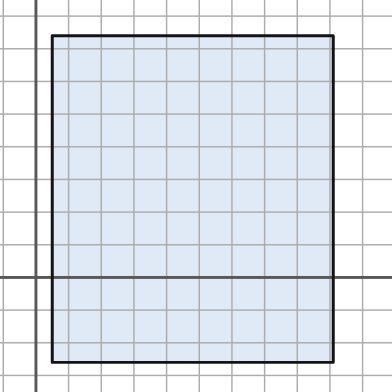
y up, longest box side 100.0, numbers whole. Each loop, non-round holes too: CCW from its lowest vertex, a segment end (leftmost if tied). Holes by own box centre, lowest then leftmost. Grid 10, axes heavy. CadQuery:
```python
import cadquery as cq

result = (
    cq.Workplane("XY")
    .moveTo(5.0, -26.0)
    .lineTo(91.0, -26.0)
    .lineTo(91.0, 74.0)
    .lineTo(5.0, 74.0)
    .close()
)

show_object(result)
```